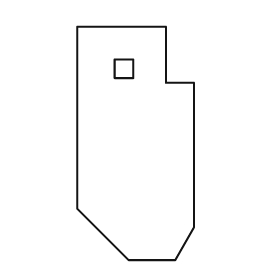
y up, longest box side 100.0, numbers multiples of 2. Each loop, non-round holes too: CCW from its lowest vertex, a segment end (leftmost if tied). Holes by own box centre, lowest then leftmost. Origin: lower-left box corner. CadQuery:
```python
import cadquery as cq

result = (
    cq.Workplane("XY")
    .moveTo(22.0, 0.0)
    .lineTo(42.0, 0.0)
    .lineTo(50.0, 14.0)
    .lineTo(50.0, 76.0)
    .lineTo(38.0, 76.0)
    .lineTo(38.0, 100.0)
    .lineTo(0.0, 100.0)
    .lineTo(0.0, 22.0)
    .close()
    .moveTo(16.0, 78.0)
    .lineTo(24.0, 78.0)
    .lineTo(24.0, 86.0)
    .lineTo(16.0, 86.0)
    .close()
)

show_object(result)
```